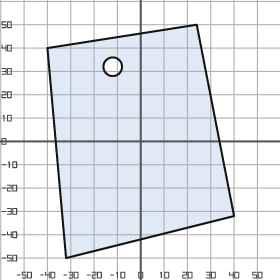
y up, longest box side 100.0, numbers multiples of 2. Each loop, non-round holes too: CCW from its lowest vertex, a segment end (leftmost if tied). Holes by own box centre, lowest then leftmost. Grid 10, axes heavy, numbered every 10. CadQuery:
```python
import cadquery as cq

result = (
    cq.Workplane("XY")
    .moveTo(-32.0, -50.0)
    .lineTo(40.0, -32.0)
    .lineTo(24.0, 50.0)
    .lineTo(-40.0, 40.0)
    .close()
    .moveTo(-12.0, 32.0)
    .circle(4.0)
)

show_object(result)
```